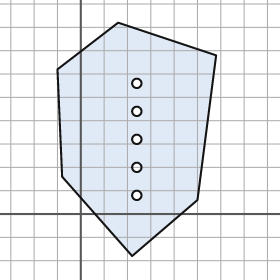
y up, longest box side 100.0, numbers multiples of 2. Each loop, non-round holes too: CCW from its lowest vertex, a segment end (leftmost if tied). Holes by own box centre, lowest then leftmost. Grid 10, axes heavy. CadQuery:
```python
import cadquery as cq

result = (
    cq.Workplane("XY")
    .moveTo(22.0, -18.0)
    .lineTo(50.0, 6.0)
    .lineTo(58.0, 68.0)
    .lineTo(16.0, 82.0)
    .lineTo(-10.0, 62.0)
    .lineTo(-8.0, 16.0)
    .close()
    .moveTo(24.0, 8.0)
    .circle(2.0)
    .moveTo(24.0, 20.0)
    .circle(2.0)
    .moveTo(24.0, 32.0)
    .circle(2.0)
    .moveTo(24.0, 44.0)
    .circle(2.0)
    .moveTo(24.0, 56.0)
    .circle(2.0)
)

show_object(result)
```